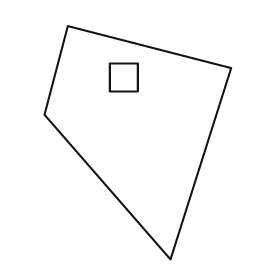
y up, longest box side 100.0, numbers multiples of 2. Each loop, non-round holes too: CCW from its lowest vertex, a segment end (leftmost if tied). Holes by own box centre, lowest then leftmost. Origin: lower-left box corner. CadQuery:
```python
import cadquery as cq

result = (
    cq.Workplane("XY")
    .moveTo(54.0, 0.0)
    .lineTo(80.0, 82.0)
    .lineTo(10.0, 100.0)
    .lineTo(0.0, 62.0)
    .close()
    .moveTo(28.0, 72.0)
    .lineTo(40.0, 72.0)
    .lineTo(40.0, 84.0)
    .lineTo(28.0, 84.0)
    .close()
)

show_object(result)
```